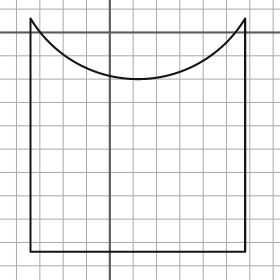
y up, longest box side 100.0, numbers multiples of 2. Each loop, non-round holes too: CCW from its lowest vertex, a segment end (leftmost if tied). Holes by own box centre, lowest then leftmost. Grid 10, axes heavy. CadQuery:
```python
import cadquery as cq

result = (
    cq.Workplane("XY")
    .moveTo(-34.0, -94.0)
    .lineTo(58.0, -94.0)
    .lineTo(58.0, 6.0)
    .threePointArc((12.0, -20.0), (-34.0, 6.0))
    .close()
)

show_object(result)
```